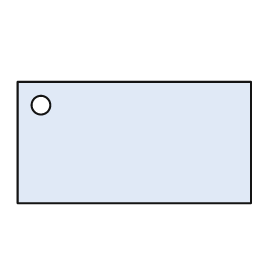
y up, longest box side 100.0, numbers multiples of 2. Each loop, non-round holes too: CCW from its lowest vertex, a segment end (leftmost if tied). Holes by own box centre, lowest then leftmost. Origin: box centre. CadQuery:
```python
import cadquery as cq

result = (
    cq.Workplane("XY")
    .moveTo(-50.0, -26.0)
    .lineTo(50.0, -26.0)
    .lineTo(50.0, 26.0)
    .lineTo(-50.0, 26.0)
    .close()
    .moveTo(-40.0, 16.0)
    .circle(4.0)
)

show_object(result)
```